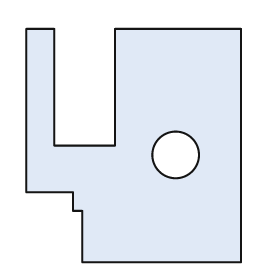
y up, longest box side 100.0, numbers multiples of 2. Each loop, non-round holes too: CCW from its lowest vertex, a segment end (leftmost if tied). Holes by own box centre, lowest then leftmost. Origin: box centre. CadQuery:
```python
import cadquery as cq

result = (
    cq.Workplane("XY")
    .moveTo(-22.0, -50.0)
    .lineTo(46.0, -50.0)
    .lineTo(46.0, 50.0)
    .lineTo(-8.0, 50.0)
    .lineTo(-8.0, 0.0)
    .lineTo(-34.0, 0.0)
    .lineTo(-34.0, 50.0)
    .lineTo(-46.0, 50.0)
    .lineTo(-46.0, -20.0)
    .lineTo(-26.0, -20.0)
    .lineTo(-26.0, -28.0)
    .lineTo(-22.0, -28.0)
    .close()
    .moveTo(18.0, -4.0)
    .circle(10.0)
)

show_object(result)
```